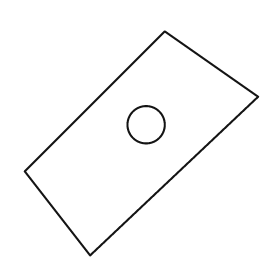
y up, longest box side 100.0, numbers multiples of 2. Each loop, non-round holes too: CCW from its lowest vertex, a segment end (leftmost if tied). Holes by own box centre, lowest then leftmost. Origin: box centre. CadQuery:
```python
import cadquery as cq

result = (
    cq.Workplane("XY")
    .moveTo(-22.0, -48.0)
    .lineTo(50.0, 20.0)
    .lineTo(10.0, 48.0)
    .lineTo(-50.0, -12.0)
    .close()
    .moveTo(2.0, 8.0)
    .circle(8.0)
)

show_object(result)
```